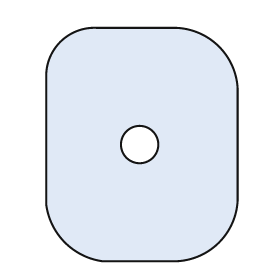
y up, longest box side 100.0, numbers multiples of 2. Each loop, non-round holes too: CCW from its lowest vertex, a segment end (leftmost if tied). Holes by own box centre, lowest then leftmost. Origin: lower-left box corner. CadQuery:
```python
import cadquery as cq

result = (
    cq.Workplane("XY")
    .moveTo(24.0, 0.0)
    .lineTo(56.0, 0.0)
    .threePointArc((74.0, 8.0), (82.0, 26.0))
    .lineTo(82.0, 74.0)
    .threePointArc((74.0, 92.0), (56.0, 100.0))
    .lineTo(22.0, 100.0)
    .threePointArc((6.0, 94.0), (0.0, 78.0))
    .lineTo(0.0, 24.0)
    .threePointArc((8.0, 8.0), (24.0, 0.0))
    .close()
    .moveTo(40.0, 50.0)
    .circle(8.0)
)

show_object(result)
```